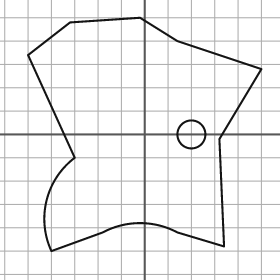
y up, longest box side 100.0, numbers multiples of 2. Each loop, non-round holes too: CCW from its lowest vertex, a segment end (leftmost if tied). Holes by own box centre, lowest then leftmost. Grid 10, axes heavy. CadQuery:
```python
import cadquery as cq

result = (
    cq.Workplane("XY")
    .moveTo(-40.0, -50.0)
    .lineTo(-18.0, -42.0)
    .threePointArc((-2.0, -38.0), (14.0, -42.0))
    .lineTo(34.0, -48.0)
    .lineTo(32.0, -2.0)
    .lineTo(50.0, 28.0)
    .lineTo(14.0, 40.0)
    .lineTo(-2.0, 50.0)
    .lineTo(-32.0, 48.0)
    .lineTo(-50.0, 34.0)
    .lineTo(-30.0, -10.0)
    .threePointArc((-42.0, -28.0), (-40.0, -50.0))
    .close()
    .moveTo(20.0, 0.0)
    .circle(6.0)
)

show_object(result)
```